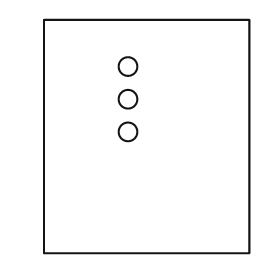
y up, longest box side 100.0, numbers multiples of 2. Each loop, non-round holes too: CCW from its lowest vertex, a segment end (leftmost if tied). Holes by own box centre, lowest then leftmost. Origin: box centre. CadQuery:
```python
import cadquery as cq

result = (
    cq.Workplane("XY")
    .moveTo(-44.0, -50.0)
    .lineTo(44.0, -50.0)
    .lineTo(44.0, 50.0)
    .lineTo(-44.0, 50.0)
    .close()
    .moveTo(-8.0, 2.0)
    .circle(4.0)
    .moveTo(-8.0, 16.0)
    .circle(4.0)
    .moveTo(-8.0, 30.0)
    .circle(4.0)
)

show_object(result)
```